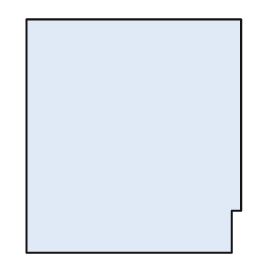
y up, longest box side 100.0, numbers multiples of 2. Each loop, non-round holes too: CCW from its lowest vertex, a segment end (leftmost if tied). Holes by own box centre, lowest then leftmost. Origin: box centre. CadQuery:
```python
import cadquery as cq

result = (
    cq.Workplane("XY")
    .moveTo(-46.0, -50.0)
    .lineTo(42.0, -50.0)
    .lineTo(42.0, -32.0)
    .lineTo(46.0, -32.0)
    .lineTo(46.0, 50.0)
    .lineTo(-46.0, 50.0)
    .close()
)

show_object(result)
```